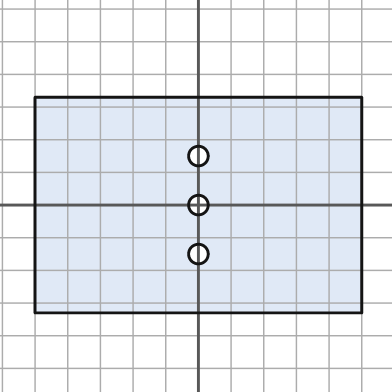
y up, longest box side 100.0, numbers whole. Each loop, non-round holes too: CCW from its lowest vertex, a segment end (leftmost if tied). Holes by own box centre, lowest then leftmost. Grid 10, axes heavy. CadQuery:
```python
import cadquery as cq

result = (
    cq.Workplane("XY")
    .moveTo(-50.0, -33.0)
    .lineTo(50.0, -33.0)
    .lineTo(50.0, 33.0)
    .lineTo(-50.0, 33.0)
    .close()
    .moveTo(0.0, -15.0)
    .circle(3.0)
    .moveTo(0.0, 0.0)
    .circle(3.0)
    .moveTo(0.0, 15.0)
    .circle(3.0)
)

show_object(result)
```